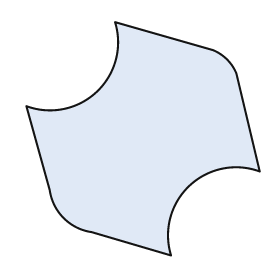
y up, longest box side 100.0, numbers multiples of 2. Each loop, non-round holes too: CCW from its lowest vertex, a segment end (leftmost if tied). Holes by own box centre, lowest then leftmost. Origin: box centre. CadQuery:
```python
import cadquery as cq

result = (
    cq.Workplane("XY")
    .moveTo(12.0, -50.0)
    .threePointArc((20.0, -20.0), (50.0, -14.0))
    .lineTo(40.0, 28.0)
    .threePointArc((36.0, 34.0), (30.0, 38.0))
    .lineTo(-12.0, 50.0)
    .threePointArc((-20.0, 20.0), (-50.0, 14.0))
    .lineTo(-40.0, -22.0)
    .threePointArc((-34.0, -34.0), (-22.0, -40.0))
    .close()
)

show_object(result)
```